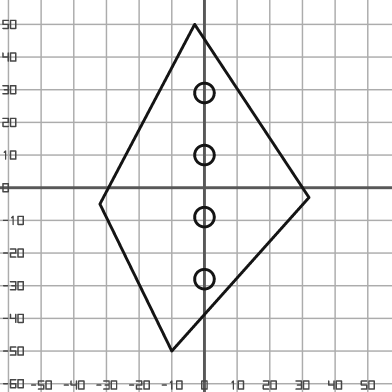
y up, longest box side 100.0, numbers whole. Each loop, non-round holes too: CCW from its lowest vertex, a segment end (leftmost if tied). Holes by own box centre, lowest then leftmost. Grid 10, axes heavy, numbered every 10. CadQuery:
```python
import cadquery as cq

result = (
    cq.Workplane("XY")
    .moveTo(-10.0, -50.0)
    .lineTo(32.0, -3.0)
    .lineTo(-3.0, 50.0)
    .lineTo(-32.0, -5.0)
    .close()
    .moveTo(0.0, -28.0)
    .circle(3.0)
    .moveTo(0.0, -9.0)
    .circle(3.0)
    .moveTo(0.0, 10.0)
    .circle(3.0)
    .moveTo(0.0, 29.0)
    .circle(3.0)
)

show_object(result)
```